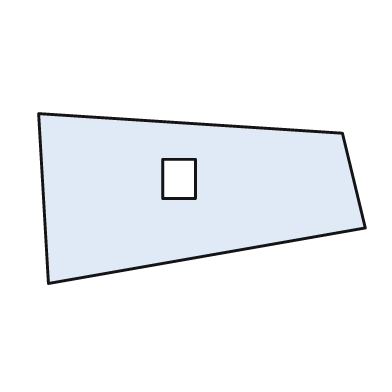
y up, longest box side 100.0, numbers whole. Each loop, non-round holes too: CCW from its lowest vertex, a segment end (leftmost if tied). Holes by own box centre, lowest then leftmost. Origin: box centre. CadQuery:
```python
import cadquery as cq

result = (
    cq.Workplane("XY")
    .moveTo(-47.0, -26.0)
    .lineTo(50.0, -9.0)
    .lineTo(43.0, 20.0)
    .lineTo(-50.0, 26.0)
    .close()
    .moveTo(-12.0, 0.0)
    .lineTo(-2.0, 0.0)
    .lineTo(-2.0, 12.0)
    .lineTo(-12.0, 12.0)
    .close()
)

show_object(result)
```